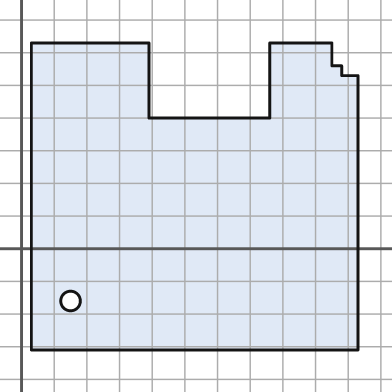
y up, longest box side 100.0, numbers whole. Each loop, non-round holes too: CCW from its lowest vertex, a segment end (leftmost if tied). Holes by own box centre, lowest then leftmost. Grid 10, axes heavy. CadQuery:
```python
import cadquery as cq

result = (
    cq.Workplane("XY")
    .moveTo(3.0, -31.0)
    .lineTo(103.0, -31.0)
    .lineTo(103.0, 53.0)
    .lineTo(98.0, 53.0)
    .lineTo(98.0, 56.0)
    .lineTo(95.0, 56.0)
    .lineTo(95.0, 63.0)
    .lineTo(76.0, 63.0)
    .lineTo(76.0, 40.0)
    .lineTo(39.0, 40.0)
    .lineTo(39.0, 63.0)
    .lineTo(3.0, 63.0)
    .close()
    .moveTo(15.0, -16.0)
    .circle(3.0)
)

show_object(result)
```